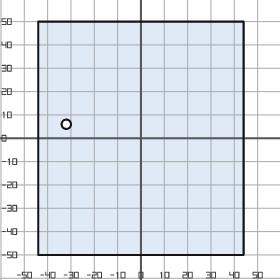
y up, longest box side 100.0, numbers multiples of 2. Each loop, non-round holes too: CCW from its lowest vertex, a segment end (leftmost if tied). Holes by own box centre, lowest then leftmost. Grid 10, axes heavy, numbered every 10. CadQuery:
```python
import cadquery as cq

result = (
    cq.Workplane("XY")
    .moveTo(-44.0, -50.0)
    .lineTo(44.0, -50.0)
    .lineTo(44.0, 50.0)
    .lineTo(-44.0, 50.0)
    .close()
    .moveTo(-32.0, 6.0)
    .circle(2.0)
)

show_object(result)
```